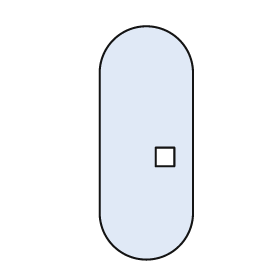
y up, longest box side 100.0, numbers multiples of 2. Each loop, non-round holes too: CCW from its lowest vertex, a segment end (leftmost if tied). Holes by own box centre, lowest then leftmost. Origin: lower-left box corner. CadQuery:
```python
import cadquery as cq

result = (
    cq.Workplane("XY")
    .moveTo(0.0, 20.0)
    .threePointArc((20.0, 0.0), (40.0, 20.0))
    .lineTo(40.0, 80.0)
    .threePointArc((20.0, 100.0), (0.0, 80.0))
    .close()
    .moveTo(24.0, 40.0)
    .lineTo(32.0, 40.0)
    .lineTo(32.0, 48.0)
    .lineTo(24.0, 48.0)
    .close()
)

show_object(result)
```